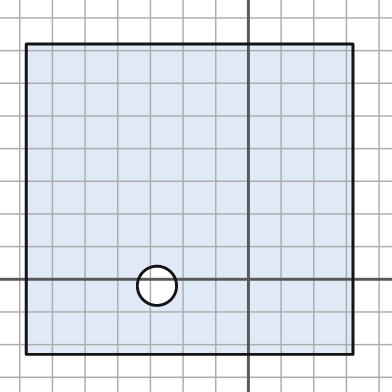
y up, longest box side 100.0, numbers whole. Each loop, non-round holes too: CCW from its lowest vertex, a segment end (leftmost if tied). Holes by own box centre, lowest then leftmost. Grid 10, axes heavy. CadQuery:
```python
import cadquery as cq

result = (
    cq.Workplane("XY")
    .moveTo(-68.0, -23.0)
    .lineTo(32.0, -23.0)
    .lineTo(32.0, 72.0)
    .lineTo(-68.0, 72.0)
    .close()
    .moveTo(-28.0, -2.0)
    .circle(6.0)
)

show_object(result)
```